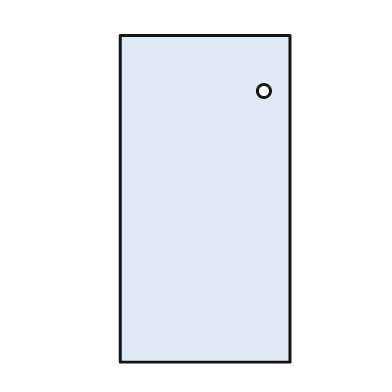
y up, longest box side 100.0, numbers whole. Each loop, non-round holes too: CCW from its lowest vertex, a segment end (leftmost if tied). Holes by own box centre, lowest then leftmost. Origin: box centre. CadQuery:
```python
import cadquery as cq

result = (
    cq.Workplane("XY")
    .moveTo(-26.0, -50.0)
    .lineTo(26.0, -50.0)
    .lineTo(26.0, 50.0)
    .lineTo(-26.0, 50.0)
    .close()
    .moveTo(18.0, 33.0)
    .circle(2.0)
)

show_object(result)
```